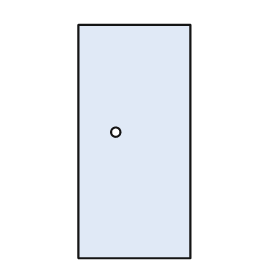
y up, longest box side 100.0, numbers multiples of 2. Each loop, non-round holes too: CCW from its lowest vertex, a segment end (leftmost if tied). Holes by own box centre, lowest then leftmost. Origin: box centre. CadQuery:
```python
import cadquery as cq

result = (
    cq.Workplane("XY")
    .moveTo(-24.0, -50.0)
    .lineTo(24.0, -50.0)
    .lineTo(24.0, 50.0)
    .lineTo(-24.0, 50.0)
    .close()
    .moveTo(-8.0, 4.0)
    .circle(2.0)
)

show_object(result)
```